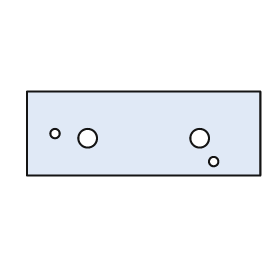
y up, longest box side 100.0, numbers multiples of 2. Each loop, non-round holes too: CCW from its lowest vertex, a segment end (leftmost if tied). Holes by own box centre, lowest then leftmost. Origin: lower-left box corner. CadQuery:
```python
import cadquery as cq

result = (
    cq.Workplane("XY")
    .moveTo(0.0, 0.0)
    .lineTo(100.0, 0.0)
    .lineTo(100.0, 36.0)
    .lineTo(0.0, 36.0)
    .close()
    .moveTo(80.0, 6.0)
    .circle(2.0)
    .moveTo(26.0, 16.0)
    .circle(4.0)
    .moveTo(74.0, 16.0)
    .circle(4.0)
    .moveTo(12.0, 18.0)
    .circle(2.0)
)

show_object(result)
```